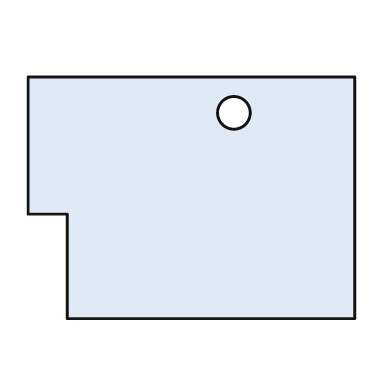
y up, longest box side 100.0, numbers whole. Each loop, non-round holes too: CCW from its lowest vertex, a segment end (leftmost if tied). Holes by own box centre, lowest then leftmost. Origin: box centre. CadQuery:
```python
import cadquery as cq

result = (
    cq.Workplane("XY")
    .moveTo(-38.0, -37.0)
    .lineTo(50.0, -37.0)
    .lineTo(50.0, 37.0)
    .lineTo(-50.0, 37.0)
    .lineTo(-50.0, -5.0)
    .lineTo(-38.0, -5.0)
    .close()
    .moveTo(13.0, 26.0)
    .circle(5.0)
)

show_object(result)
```